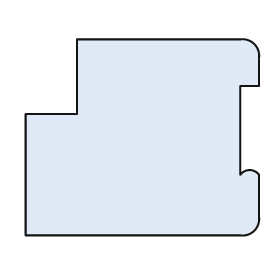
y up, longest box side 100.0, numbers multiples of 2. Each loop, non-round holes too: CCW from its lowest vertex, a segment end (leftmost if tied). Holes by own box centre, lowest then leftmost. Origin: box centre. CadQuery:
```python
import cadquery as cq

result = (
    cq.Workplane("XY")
    .moveTo(-50.0, -42.0)
    .lineTo(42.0, -42.0)
    .threePointArc((48.0, -40.0), (50.0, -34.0))
    .lineTo(50.0, -16.0)
    .threePointArc((46.0, -14.0), (42.0, -16.0))
    .lineTo(42.0, 22.0)
    .lineTo(50.0, 22.0)
    .lineTo(50.0, 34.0)
    .threePointArc((48.0, 40.0), (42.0, 42.0))
    .lineTo(-28.0, 42.0)
    .lineTo(-28.0, 10.0)
    .lineTo(-50.0, 10.0)
    .close()
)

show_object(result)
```